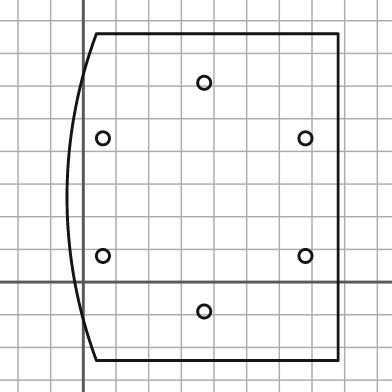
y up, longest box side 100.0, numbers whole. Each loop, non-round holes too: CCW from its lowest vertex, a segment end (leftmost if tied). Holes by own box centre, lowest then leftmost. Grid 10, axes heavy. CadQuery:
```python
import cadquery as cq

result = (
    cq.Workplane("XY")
    .moveTo(4.0, -24.0)
    .lineTo(78.0, -24.0)
    .lineTo(78.0, 76.0)
    .lineTo(4.0, 76.0)
    .threePointArc((-5.0, 26.0), (4.0, -24.0))
    .close()
    .moveTo(37.0, -9.0)
    .circle(2.0)
    .moveTo(6.0, 8.0)
    .circle(2.0)
    .moveTo(68.0, 8.0)
    .circle(2.0)
    .moveTo(6.0, 44.0)
    .circle(2.0)
    .moveTo(68.0, 44.0)
    .circle(2.0)
    .moveTo(37.0, 61.0)
    .circle(2.0)
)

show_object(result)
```